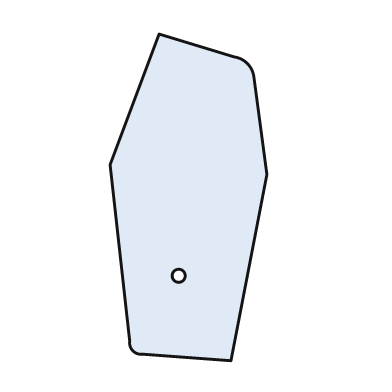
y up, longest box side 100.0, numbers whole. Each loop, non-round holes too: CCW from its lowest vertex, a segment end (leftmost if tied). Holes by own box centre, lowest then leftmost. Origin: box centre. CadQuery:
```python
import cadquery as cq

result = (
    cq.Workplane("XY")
    .moveTo(13.0, -50.0)
    .lineTo(24.0, 7.0)
    .lineTo(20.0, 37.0)
    .threePointArc((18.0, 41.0), (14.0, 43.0))
    .lineTo(-9.0, 50.0)
    .lineTo(-24.0, 10.0)
    .lineTo(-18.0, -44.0)
    .threePointArc((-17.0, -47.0), (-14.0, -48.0))
    .close()
    .moveTo(-3.0, -24.0)
    .circle(2.0)
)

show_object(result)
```